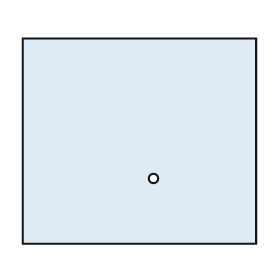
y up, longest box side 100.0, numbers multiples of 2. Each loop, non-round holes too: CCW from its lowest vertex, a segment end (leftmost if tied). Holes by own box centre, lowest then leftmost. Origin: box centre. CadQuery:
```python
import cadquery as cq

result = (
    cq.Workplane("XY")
    .moveTo(-50.0, -44.0)
    .lineTo(50.0, -44.0)
    .lineTo(50.0, 44.0)
    .lineTo(-50.0, 44.0)
    .close()
    .moveTo(6.0, -16.0)
    .circle(2.0)
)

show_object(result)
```